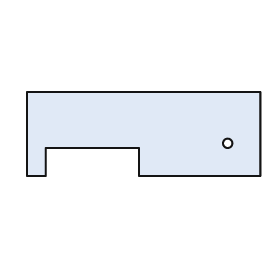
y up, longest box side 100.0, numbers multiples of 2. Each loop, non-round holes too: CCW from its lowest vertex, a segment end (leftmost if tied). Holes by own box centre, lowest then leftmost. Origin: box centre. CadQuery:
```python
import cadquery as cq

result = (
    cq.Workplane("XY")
    .moveTo(-50.0, -18.0)
    .lineTo(-42.0, -18.0)
    .lineTo(-42.0, -6.0)
    .lineTo(-2.0, -6.0)
    .lineTo(-2.0, -18.0)
    .lineTo(50.0, -18.0)
    .lineTo(50.0, 18.0)
    .lineTo(-50.0, 18.0)
    .close()
    .moveTo(36.0, -4.0)
    .circle(2.0)
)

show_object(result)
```